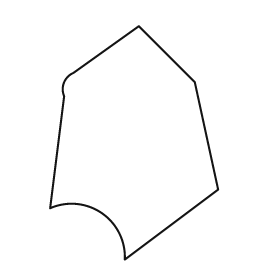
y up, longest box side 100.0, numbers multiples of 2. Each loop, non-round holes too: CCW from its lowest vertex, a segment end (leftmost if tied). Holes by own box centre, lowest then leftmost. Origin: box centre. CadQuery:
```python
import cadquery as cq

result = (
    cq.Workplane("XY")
    .moveTo(-4.0, -50.0)
    .lineTo(36.0, -20.0)
    .lineTo(26.0, 26.0)
    .lineTo(2.0, 50.0)
    .lineTo(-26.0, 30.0)
    .threePointArc((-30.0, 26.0), (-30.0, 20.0))
    .lineTo(-36.0, -28.0)
    .threePointArc((-14.0, -30.0), (-4.0, -50.0))
    .close()
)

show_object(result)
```